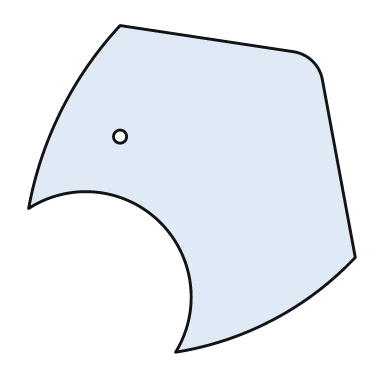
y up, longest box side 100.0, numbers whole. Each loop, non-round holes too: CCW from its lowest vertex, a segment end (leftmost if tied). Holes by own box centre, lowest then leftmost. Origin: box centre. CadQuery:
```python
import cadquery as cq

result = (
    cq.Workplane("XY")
    .moveTo(-5.0, -50.0)
    .threePointArc((25.0, -40.0), (50.0, -21.0))
    .lineTo(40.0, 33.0)
    .threePointArc((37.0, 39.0), (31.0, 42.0))
    .lineTo(-22.0, 50.0)
    .threePointArc((-40.0, 24.0), (-50.0, -6.0))
    .threePointArc((-10.0, -10.0), (-5.0, -50.0))
    .close()
    .moveTo(-22.0, 16.0)
    .circle(2.0)
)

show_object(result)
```